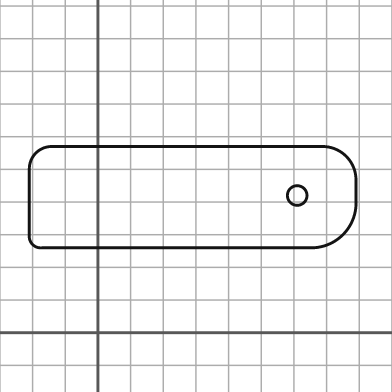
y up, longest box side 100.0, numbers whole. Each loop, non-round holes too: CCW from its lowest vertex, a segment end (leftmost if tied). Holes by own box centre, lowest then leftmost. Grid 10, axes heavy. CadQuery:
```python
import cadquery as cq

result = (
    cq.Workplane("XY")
    .moveTo(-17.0, 26.0)
    .lineTo(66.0, 26.0)
    .threePointArc((75.0, 30.0), (79.0, 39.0))
    .lineTo(79.0, 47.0)
    .threePointArc((76.0, 54.0), (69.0, 57.0))
    .lineTo(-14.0, 57.0)
    .threePointArc((-19.0, 55.0), (-21.0, 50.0))
    .lineTo(-21.0, 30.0)
    .threePointArc((-20.0, 27.0), (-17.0, 26.0))
    .close()
    .moveTo(61.0, 42.0)
    .circle(3.0)
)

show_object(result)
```